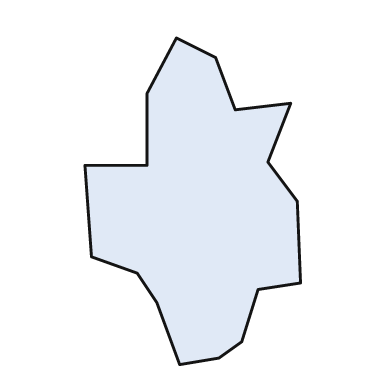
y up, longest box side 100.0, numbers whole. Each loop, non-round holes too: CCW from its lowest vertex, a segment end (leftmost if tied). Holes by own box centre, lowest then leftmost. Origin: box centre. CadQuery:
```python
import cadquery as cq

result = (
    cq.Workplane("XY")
    .moveTo(-4.0, -50.0)
    .lineTo(8.0, -48.0)
    .lineTo(15.0, -43.0)
    .lineTo(20.0, -27.0)
    .lineTo(33.0, -25.0)
    .lineTo(32.0, 0.0)
    .lineTo(23.0, 12.0)
    .lineTo(30.0, 30.0)
    .lineTo(13.0, 28.0)
    .lineTo(7.0, 44.0)
    .lineTo(-5.0, 50.0)
    .lineTo(-14.0, 33.0)
    .lineTo(-14.0, 11.0)
    .lineTo(-33.0, 11.0)
    .lineTo(-31.0, -17.0)
    .lineTo(-17.0, -22.0)
    .lineTo(-11.0, -31.0)
    .close()
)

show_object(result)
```